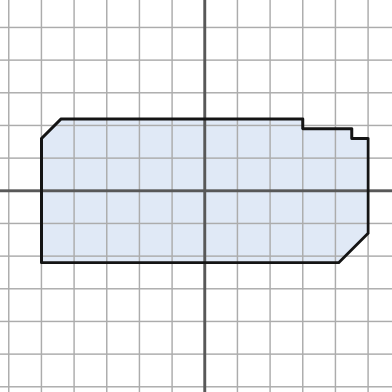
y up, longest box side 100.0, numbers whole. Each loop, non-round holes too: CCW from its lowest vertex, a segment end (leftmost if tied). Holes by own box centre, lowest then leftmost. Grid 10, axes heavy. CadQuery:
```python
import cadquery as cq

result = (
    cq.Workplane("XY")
    .moveTo(-50.0, -22.0)
    .lineTo(41.0, -22.0)
    .lineTo(50.0, -13.0)
    .lineTo(50.0, 16.0)
    .lineTo(45.0, 16.0)
    .lineTo(45.0, 19.0)
    .lineTo(30.0, 19.0)
    .lineTo(30.0, 22.0)
    .lineTo(-44.0, 22.0)
    .lineTo(-50.0, 16.0)
    .close()
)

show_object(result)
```